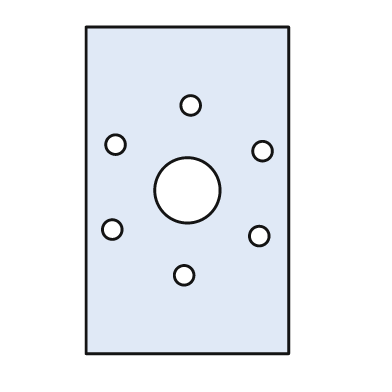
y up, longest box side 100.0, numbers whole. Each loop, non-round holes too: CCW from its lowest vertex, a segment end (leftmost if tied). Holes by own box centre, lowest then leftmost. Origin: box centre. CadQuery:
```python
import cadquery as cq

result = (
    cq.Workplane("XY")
    .moveTo(-31.0, -50.0)
    .lineTo(31.0, -50.0)
    .lineTo(31.0, 50.0)
    .lineTo(-31.0, 50.0)
    .close()
    .moveTo(-1.0, -26.0)
    .circle(3.0)
    .moveTo(22.0, -14.0)
    .circle(3.0)
    .moveTo(-23.0, -12.0)
    .circle(3.0)
    .moveTo(0.0, 0.0)
    .circle(10.0)
    .moveTo(23.0, 12.0)
    .circle(3.0)
    .moveTo(-22.0, 14.0)
    .circle(3.0)
    .moveTo(1.0, 26.0)
    .circle(3.0)
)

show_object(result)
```